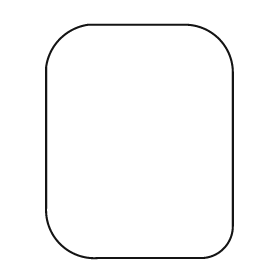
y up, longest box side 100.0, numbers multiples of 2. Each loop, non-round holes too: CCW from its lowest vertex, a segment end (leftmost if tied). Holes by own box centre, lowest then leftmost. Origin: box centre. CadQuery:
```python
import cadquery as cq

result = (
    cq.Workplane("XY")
    .moveTo(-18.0, -50.0)
    .lineTo(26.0, -50.0)
    .threePointArc((36.0, -46.0), (40.0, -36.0))
    .lineTo(40.0, 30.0)
    .threePointArc((34.0, 44.0), (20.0, 50.0))
    .lineTo(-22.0, 50.0)
    .threePointArc((-34.0, 44.0), (-40.0, 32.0))
    .lineTo(-40.0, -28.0)
    .threePointArc((-34.0, -44.0), (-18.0, -50.0))
    .close()
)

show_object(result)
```